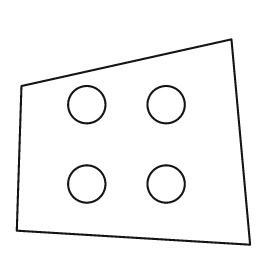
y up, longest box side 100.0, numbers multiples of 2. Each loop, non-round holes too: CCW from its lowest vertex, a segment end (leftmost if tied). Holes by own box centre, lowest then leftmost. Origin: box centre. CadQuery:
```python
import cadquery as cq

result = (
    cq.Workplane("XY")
    .moveTo(50.0, -44.0)
    .lineTo(42.0, 44.0)
    .lineTo(-48.0, 24.0)
    .lineTo(-50.0, -38.0)
    .close()
    .moveTo(-20.0, -18.0)
    .circle(8.0)
    .moveTo(14.0, -18.0)
    .circle(8.0)
    .moveTo(-20.0, 16.0)
    .circle(8.0)
    .moveTo(14.0, 16.0)
    .circle(8.0)
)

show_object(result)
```